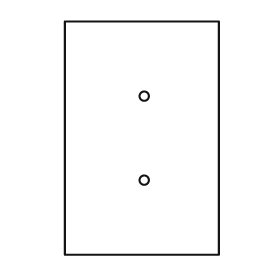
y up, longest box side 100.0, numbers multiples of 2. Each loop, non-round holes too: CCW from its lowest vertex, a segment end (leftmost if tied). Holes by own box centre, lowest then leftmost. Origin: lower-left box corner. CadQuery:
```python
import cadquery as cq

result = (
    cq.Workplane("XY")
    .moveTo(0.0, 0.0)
    .lineTo(66.0, 0.0)
    .lineTo(66.0, 100.0)
    .lineTo(0.0, 100.0)
    .close()
    .moveTo(34.0, 32.0)
    .circle(2.0)
    .moveTo(34.0, 68.0)
    .circle(2.0)
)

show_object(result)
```